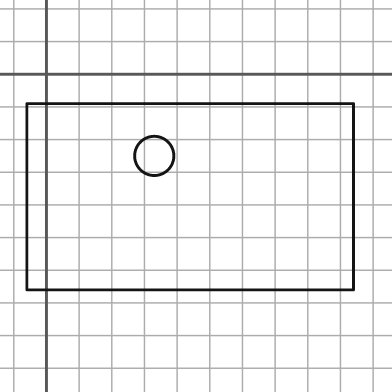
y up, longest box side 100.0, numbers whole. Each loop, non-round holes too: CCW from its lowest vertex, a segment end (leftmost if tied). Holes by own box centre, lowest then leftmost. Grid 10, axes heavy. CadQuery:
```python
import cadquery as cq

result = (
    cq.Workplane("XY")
    .moveTo(-6.0, -66.0)
    .lineTo(94.0, -66.0)
    .lineTo(94.0, -9.0)
    .lineTo(-6.0, -9.0)
    .close()
    .moveTo(33.0, -25.0)
    .circle(6.0)
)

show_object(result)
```